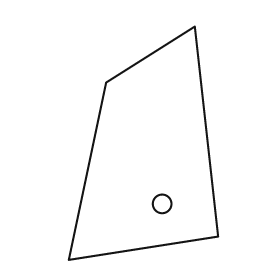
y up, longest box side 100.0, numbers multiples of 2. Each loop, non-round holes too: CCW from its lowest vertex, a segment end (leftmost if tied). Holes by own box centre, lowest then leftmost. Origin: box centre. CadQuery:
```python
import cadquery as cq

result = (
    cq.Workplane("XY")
    .moveTo(-32.0, -50.0)
    .lineTo(32.0, -40.0)
    .lineTo(22.0, 50.0)
    .lineTo(-16.0, 26.0)
    .close()
    .moveTo(8.0, -26.0)
    .circle(4.0)
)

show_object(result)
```